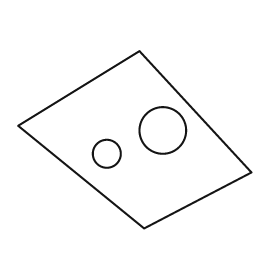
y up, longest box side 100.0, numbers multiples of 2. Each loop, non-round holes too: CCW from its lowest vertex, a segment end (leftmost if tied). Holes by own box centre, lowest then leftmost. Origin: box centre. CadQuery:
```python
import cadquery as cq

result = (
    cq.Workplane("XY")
    .moveTo(4.0, -38.0)
    .lineTo(50.0, -14.0)
    .lineTo(2.0, 38.0)
    .lineTo(-50.0, 6.0)
    .close()
    .moveTo(-12.0, -6.0)
    .circle(6.0)
    .moveTo(12.0, 4.0)
    .circle(10.0)
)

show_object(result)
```